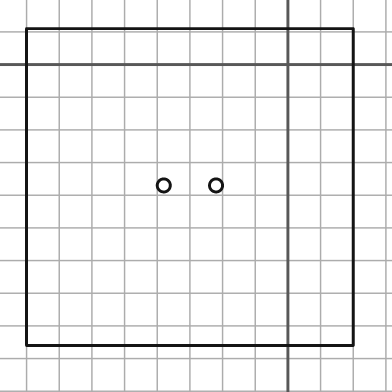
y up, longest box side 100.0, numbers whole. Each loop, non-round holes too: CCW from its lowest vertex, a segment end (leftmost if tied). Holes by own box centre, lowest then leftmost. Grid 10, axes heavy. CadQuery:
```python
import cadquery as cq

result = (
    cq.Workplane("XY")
    .moveTo(-80.0, -86.0)
    .lineTo(20.0, -86.0)
    .lineTo(20.0, 11.0)
    .lineTo(-80.0, 11.0)
    .close()
    .moveTo(-38.0, -37.0)
    .circle(2.0)
    .moveTo(-22.0, -37.0)
    .circle(2.0)
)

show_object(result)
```